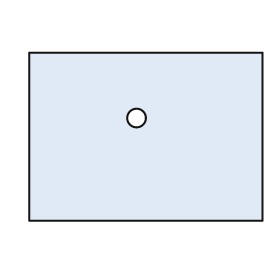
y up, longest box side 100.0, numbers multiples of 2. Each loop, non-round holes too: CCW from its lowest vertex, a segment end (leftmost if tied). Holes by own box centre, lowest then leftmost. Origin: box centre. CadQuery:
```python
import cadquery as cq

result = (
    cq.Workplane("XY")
    .moveTo(-50.0, -36.0)
    .lineTo(50.0, -36.0)
    .lineTo(50.0, 36.0)
    .lineTo(-50.0, 36.0)
    .close()
    .moveTo(-4.0, 8.0)
    .circle(4.0)
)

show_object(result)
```